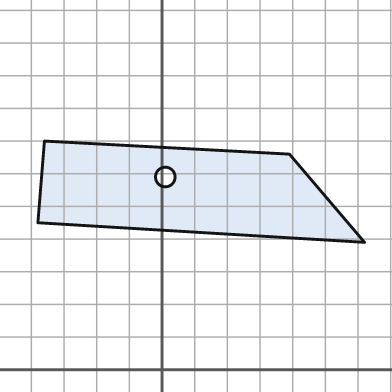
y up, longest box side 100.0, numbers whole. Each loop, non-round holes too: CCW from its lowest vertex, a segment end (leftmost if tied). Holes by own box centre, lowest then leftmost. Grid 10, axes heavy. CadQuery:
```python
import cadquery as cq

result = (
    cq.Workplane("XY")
    .moveTo(62.0, 39.0)
    .lineTo(39.0, 66.0)
    .lineTo(-36.0, 70.0)
    .lineTo(-38.0, 45.0)
    .close()
    .moveTo(1.0, 59.0)
    .circle(3.0)
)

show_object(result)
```